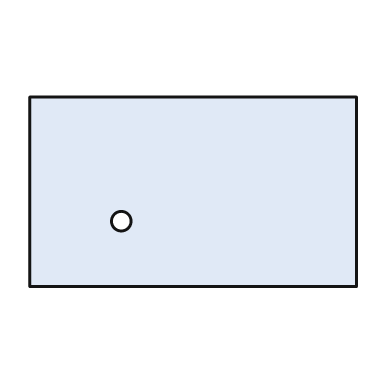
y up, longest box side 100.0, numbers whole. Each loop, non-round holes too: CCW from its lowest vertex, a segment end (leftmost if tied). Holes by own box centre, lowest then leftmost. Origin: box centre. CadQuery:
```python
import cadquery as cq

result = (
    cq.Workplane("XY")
    .moveTo(-50.0, -29.0)
    .lineTo(50.0, -29.0)
    .lineTo(50.0, 29.0)
    .lineTo(-50.0, 29.0)
    .close()
    .moveTo(-22.0, -9.0)
    .circle(3.0)
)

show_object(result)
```